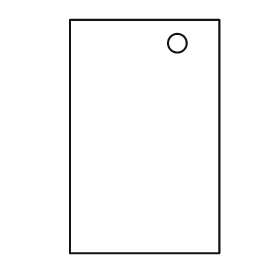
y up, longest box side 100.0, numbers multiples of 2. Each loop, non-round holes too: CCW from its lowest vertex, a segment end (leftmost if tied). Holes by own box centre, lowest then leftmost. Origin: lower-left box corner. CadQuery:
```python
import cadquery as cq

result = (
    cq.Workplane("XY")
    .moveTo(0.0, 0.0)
    .lineTo(64.0, 0.0)
    .lineTo(64.0, 100.0)
    .lineTo(0.0, 100.0)
    .close()
    .moveTo(46.0, 90.0)
    .circle(4.0)
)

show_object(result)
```